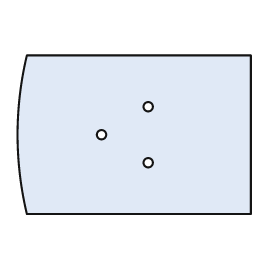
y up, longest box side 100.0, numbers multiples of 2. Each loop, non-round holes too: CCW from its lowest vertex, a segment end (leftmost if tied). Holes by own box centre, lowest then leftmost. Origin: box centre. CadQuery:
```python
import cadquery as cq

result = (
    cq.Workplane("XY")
    .moveTo(-46.0, -34.0)
    .lineTo(50.0, -34.0)
    .lineTo(50.0, 34.0)
    .lineTo(-46.0, 34.0)
    .threePointArc((-50.0, 0.0), (-46.0, -34.0))
    .close()
    .moveTo(6.0, -12.0)
    .circle(2.0)
    .moveTo(-14.0, 0.0)
    .circle(2.0)
    .moveTo(6.0, 12.0)
    .circle(2.0)
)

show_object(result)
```